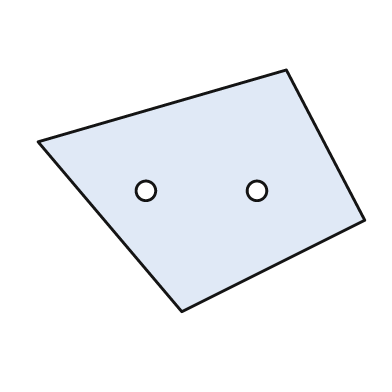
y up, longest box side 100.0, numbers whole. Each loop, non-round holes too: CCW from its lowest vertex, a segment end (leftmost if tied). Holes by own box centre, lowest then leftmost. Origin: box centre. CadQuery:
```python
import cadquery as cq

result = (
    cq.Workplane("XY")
    .moveTo(-6.0, -37.0)
    .lineTo(50.0, -9.0)
    .lineTo(26.0, 37.0)
    .lineTo(-50.0, 15.0)
    .close()
    .moveTo(-17.0, 0.0)
    .circle(3.0)
    .moveTo(17.0, 0.0)
    .circle(3.0)
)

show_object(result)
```